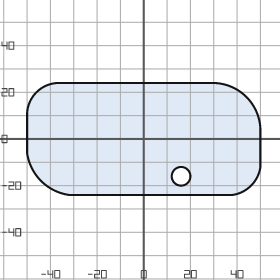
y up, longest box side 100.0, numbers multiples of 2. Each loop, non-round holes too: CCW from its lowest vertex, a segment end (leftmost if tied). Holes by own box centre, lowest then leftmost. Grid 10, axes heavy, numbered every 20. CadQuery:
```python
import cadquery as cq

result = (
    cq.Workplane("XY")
    .moveTo(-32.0, -24.0)
    .lineTo(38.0, -24.0)
    .threePointArc((46.0, -20.0), (50.0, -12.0))
    .lineTo(50.0, 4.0)
    .threePointArc((44.0, 18.0), (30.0, 24.0))
    .lineTo(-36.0, 24.0)
    .threePointArc((-46.0, 20.0), (-50.0, 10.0))
    .lineTo(-50.0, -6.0)
    .threePointArc((-44.0, -18.0), (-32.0, -24.0))
    .close()
    .moveTo(16.0, -16.0)
    .circle(4.0)
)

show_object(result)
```